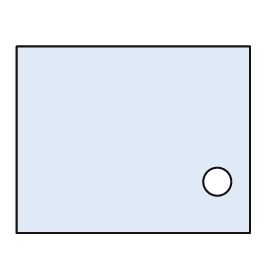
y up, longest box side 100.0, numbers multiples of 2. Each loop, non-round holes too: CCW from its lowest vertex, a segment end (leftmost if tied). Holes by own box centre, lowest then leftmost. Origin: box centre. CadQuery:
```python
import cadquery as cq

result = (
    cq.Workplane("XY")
    .moveTo(-50.0, -40.0)
    .lineTo(50.0, -40.0)
    .lineTo(50.0, 40.0)
    .lineTo(-50.0, 40.0)
    .close()
    .moveTo(36.0, -18.0)
    .circle(6.0)
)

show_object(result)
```